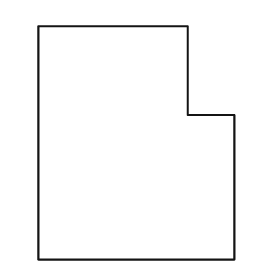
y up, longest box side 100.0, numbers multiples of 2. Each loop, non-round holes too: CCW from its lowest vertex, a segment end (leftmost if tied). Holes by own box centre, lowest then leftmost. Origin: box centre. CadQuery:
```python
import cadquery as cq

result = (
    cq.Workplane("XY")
    .moveTo(-42.0, -50.0)
    .lineTo(42.0, -50.0)
    .lineTo(42.0, 12.0)
    .lineTo(22.0, 12.0)
    .lineTo(22.0, 50.0)
    .lineTo(-42.0, 50.0)
    .close()
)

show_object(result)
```